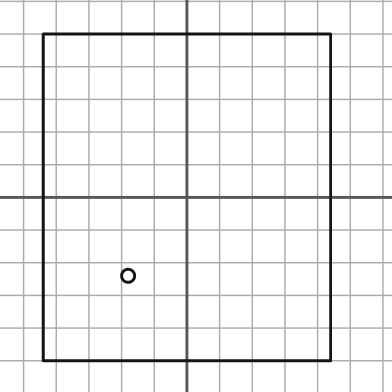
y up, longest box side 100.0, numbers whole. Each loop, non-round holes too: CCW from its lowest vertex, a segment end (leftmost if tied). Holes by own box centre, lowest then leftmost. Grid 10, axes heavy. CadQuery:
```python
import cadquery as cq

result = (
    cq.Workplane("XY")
    .moveTo(-44.0, -50.0)
    .lineTo(44.0, -50.0)
    .lineTo(44.0, 50.0)
    .lineTo(-44.0, 50.0)
    .close()
    .moveTo(-18.0, -24.0)
    .circle(2.0)
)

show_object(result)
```